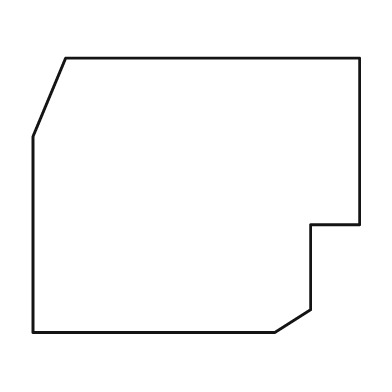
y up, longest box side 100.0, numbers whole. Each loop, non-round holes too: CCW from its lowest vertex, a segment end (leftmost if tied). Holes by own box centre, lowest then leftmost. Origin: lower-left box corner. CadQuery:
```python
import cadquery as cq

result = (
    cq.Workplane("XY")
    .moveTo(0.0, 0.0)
    .lineTo(74.0, 0.0)
    .lineTo(85.0, 7.0)
    .lineTo(85.0, 33.0)
    .lineTo(100.0, 33.0)
    .lineTo(100.0, 84.0)
    .lineTo(10.0, 84.0)
    .lineTo(0.0, 60.0)
    .close()
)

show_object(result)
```